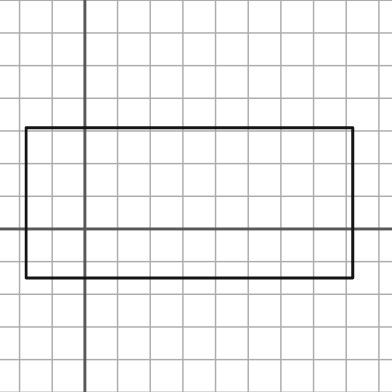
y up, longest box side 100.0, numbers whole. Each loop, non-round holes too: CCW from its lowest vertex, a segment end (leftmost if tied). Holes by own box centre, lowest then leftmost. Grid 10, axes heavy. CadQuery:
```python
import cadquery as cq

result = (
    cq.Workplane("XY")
    .moveTo(-18.0, -15.0)
    .lineTo(82.0, -15.0)
    .lineTo(82.0, 31.0)
    .lineTo(-18.0, 31.0)
    .close()
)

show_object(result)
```